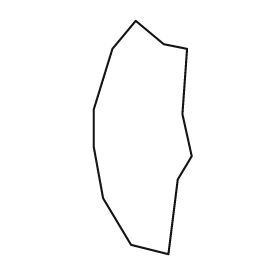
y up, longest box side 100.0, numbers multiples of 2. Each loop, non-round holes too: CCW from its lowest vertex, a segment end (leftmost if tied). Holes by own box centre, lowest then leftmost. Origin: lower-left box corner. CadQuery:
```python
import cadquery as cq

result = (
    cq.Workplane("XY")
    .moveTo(32.0, 0.0)
    .lineTo(36.0, 32.0)
    .lineTo(42.0, 42.0)
    .lineTo(38.0, 60.0)
    .lineTo(40.0, 88.0)
    .lineTo(30.0, 90.0)
    .lineTo(18.0, 100.0)
    .lineTo(8.0, 88.0)
    .lineTo(0.0, 62.0)
    .lineTo(0.0, 46.0)
    .lineTo(4.0, 24.0)
    .lineTo(16.0, 4.0)
    .close()
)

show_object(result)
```